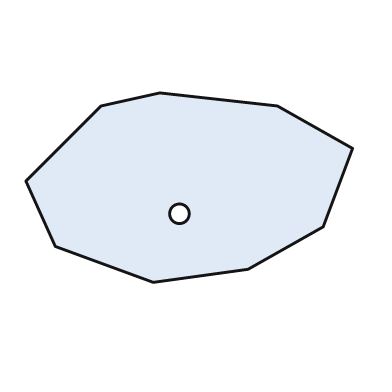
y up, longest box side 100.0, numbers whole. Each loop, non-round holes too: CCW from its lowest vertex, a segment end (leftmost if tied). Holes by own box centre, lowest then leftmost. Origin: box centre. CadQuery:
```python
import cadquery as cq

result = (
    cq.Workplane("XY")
    .moveTo(-11.0, -29.0)
    .lineTo(18.0, -25.0)
    .lineTo(41.0, -12.0)
    .lineTo(50.0, 12.0)
    .lineTo(27.0, 25.0)
    .lineTo(-9.0, 29.0)
    .lineTo(-27.0, 25.0)
    .lineTo(-50.0, 2.0)
    .lineTo(-41.0, -18.0)
    .close()
    .moveTo(-3.0, -8.0)
    .circle(3.0)
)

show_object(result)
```